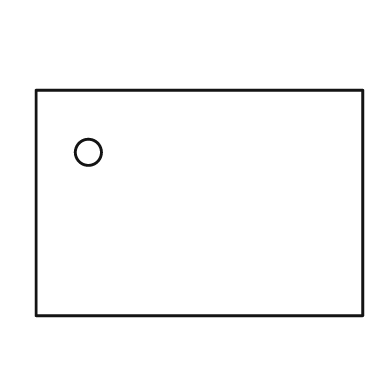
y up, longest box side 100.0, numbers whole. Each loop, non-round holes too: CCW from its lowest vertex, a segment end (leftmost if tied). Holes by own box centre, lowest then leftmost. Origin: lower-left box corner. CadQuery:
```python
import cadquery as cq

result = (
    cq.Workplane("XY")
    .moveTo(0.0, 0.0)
    .lineTo(100.0, 0.0)
    .lineTo(100.0, 69.0)
    .lineTo(0.0, 69.0)
    .close()
    .moveTo(16.0, 50.0)
    .circle(4.0)
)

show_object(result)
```